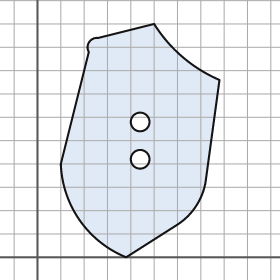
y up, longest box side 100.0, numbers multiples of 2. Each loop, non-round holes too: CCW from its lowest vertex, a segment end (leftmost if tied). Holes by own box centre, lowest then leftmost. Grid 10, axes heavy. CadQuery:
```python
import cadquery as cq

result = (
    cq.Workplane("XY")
    .moveTo(38.0, 0.0)
    .lineTo(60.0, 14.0)
    .threePointArc((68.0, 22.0), (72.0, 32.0))
    .lineTo(78.0, 76.0)
    .threePointArc((62.0, 86.0), (50.0, 100.0))
    .lineTo(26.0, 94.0)
    .threePointArc((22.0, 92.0), (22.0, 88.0))
    .lineTo(10.0, 40.0)
    .threePointArc((18.0, 16.0), (38.0, 0.0))
    .close()
    .moveTo(44.0, 42.0)
    .circle(4.0)
    .moveTo(44.0, 58.0)
    .circle(4.0)
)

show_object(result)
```